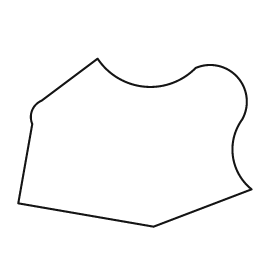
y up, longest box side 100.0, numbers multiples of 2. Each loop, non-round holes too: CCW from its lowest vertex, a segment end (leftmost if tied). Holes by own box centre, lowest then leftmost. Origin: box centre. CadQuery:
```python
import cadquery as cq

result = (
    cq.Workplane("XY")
    .moveTo(8.0, -36.0)
    .lineTo(50.0, -20.0)
    .threePointArc((42.0, -6.0), (46.0, 10.0))
    .threePointArc((44.0, 28.0), (26.0, 32.0))
    .threePointArc((4.0, 24.0), (-16.0, 36.0))
    .lineTo(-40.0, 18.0)
    .threePointArc((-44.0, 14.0), (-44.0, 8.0))
    .lineTo(-50.0, -26.0)
    .close()
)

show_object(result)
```